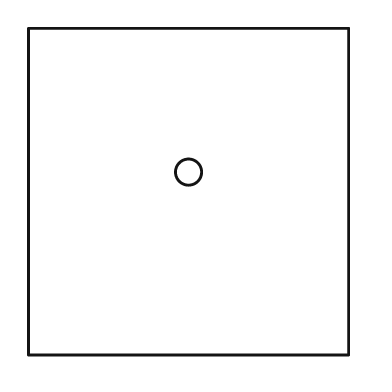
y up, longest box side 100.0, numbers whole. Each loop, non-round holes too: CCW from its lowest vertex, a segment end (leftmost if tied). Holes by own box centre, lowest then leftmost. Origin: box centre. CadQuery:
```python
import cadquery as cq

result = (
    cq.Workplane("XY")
    .moveTo(-49.0, -50.0)
    .lineTo(49.0, -50.0)
    .lineTo(49.0, 50.0)
    .lineTo(-49.0, 50.0)
    .close()
    .moveTo(0.0, 6.0)
    .circle(4.0)
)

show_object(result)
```